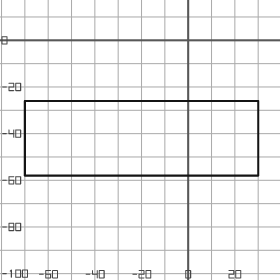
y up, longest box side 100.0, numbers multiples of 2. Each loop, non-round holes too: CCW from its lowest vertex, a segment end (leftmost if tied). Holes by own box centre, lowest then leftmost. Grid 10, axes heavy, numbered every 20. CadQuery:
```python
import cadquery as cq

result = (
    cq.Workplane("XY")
    .moveTo(-70.0, -58.0)
    .lineTo(30.0, -58.0)
    .lineTo(30.0, -26.0)
    .lineTo(-70.0, -26.0)
    .close()
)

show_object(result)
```